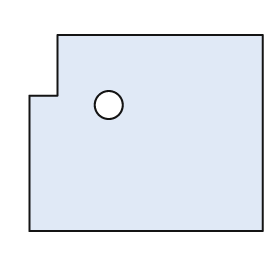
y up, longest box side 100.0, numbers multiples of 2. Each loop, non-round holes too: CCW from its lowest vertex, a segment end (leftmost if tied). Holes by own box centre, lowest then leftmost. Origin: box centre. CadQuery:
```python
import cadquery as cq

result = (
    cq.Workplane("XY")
    .moveTo(-50.0, -42.0)
    .lineTo(50.0, -42.0)
    .lineTo(50.0, 42.0)
    .lineTo(-38.0, 42.0)
    .lineTo(-38.0, 16.0)
    .lineTo(-50.0, 16.0)
    .close()
    .moveTo(-16.0, 12.0)
    .circle(6.0)
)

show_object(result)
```